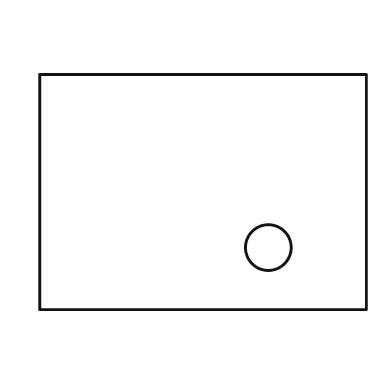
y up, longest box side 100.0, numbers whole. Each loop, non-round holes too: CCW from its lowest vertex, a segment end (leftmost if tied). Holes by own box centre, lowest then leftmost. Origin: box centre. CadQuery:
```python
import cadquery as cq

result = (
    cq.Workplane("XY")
    .moveTo(-50.0, -36.0)
    .lineTo(50.0, -36.0)
    .lineTo(50.0, 36.0)
    .lineTo(-50.0, 36.0)
    .close()
    .moveTo(20.0, -17.0)
    .circle(7.0)
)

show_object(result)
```